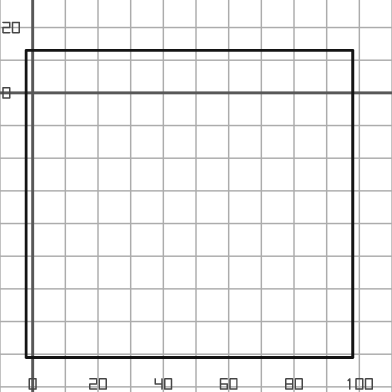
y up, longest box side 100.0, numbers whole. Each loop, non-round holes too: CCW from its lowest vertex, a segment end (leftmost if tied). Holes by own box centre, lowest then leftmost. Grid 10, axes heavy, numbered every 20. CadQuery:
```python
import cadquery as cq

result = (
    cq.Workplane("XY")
    .moveTo(-2.0, -81.0)
    .lineTo(98.0, -81.0)
    .lineTo(98.0, 13.0)
    .lineTo(-2.0, 13.0)
    .close()
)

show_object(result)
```